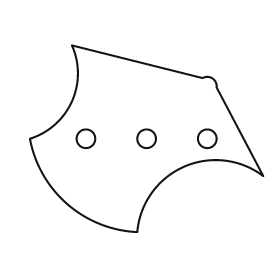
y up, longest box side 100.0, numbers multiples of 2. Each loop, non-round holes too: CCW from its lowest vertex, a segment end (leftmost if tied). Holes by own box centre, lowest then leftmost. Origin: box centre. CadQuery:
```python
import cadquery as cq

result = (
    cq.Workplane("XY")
    .moveTo(-4.0, -40.0)
    .threePointArc((16.0, -12.0), (50.0, -16.0))
    .lineTo(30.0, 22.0)
    .threePointArc((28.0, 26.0), (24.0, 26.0))
    .lineTo(-32.0, 40.0)
    .threePointArc((-32.0, 16.0), (-50.0, 0.0))
    .threePointArc((-34.0, -28.0), (-4.0, -40.0))
    .close()
    .moveTo(-26.0, 0.0)
    .circle(4.0)
    .moveTo(0.0, 0.0)
    .circle(4.0)
    .moveTo(26.0, 0.0)
    .circle(4.0)
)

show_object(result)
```